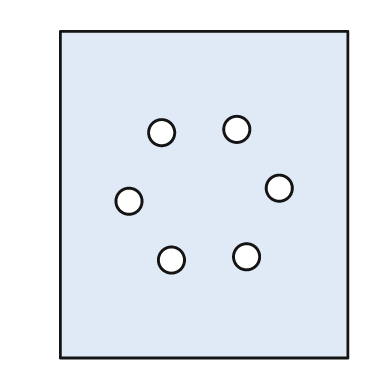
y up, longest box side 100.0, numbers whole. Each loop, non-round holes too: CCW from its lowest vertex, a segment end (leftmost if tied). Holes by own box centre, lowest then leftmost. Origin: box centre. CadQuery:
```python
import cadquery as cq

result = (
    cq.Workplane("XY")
    .moveTo(-44.0, -50.0)
    .lineTo(44.0, -50.0)
    .lineTo(44.0, 50.0)
    .lineTo(-44.0, 50.0)
    .close()
    .moveTo(-10.0, -20.0)
    .circle(4.0)
    .moveTo(13.0, -19.0)
    .circle(4.0)
    .moveTo(-23.0, -2.0)
    .circle(4.0)
    .moveTo(23.0, 2.0)
    .circle(4.0)
    .moveTo(-13.0, 19.0)
    .circle(4.0)
    .moveTo(10.0, 20.0)
    .circle(4.0)
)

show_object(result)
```